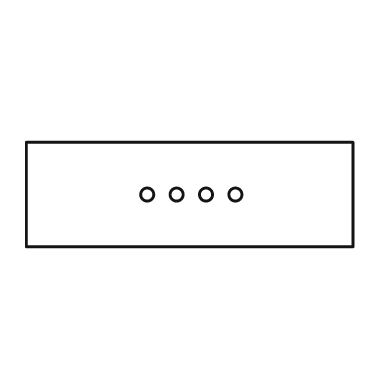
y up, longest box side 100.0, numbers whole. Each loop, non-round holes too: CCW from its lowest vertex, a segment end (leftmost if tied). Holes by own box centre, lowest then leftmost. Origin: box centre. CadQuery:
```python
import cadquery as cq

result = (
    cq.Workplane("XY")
    .moveTo(-50.0, -16.0)
    .lineTo(50.0, -16.0)
    .lineTo(50.0, 16.0)
    .lineTo(-50.0, 16.0)
    .close()
    .moveTo(-13.0, 0.0)
    .circle(2.0)
    .moveTo(-4.0, 0.0)
    .circle(2.0)
    .moveTo(5.0, 0.0)
    .circle(2.0)
    .moveTo(14.0, 0.0)
    .circle(2.0)
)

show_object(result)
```